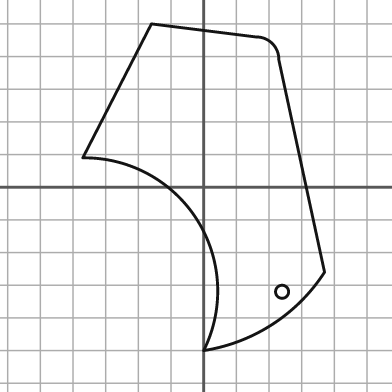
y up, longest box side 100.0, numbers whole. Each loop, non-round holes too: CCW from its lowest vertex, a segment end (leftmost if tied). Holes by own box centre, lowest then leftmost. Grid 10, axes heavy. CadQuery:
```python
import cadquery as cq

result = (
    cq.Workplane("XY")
    .moveTo(0.0, -50.0)
    .threePointArc((21.0, -42.0), (37.0, -26.0))
    .lineTo(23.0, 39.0)
    .threePointArc((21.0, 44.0), (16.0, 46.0))
    .lineTo(-16.0, 50.0)
    .lineTo(-37.0, 9.0)
    .threePointArc((-2.0, -10.0), (0.0, -50.0))
    .close()
    .moveTo(24.0, -32.0)
    .circle(2.0)
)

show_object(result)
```